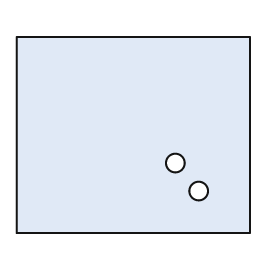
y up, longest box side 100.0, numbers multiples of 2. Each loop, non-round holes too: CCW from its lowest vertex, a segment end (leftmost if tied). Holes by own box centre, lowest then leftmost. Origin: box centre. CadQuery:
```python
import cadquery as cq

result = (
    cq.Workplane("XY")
    .moveTo(-50.0, -42.0)
    .lineTo(50.0, -42.0)
    .lineTo(50.0, 42.0)
    .lineTo(-50.0, 42.0)
    .close()
    .moveTo(28.0, -24.0)
    .circle(4.0)
    .moveTo(18.0, -12.0)
    .circle(4.0)
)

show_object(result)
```